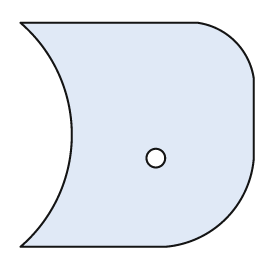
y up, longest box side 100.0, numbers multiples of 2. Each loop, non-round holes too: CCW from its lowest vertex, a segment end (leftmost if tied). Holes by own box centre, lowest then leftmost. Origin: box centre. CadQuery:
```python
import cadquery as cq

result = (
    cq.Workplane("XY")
    .moveTo(-50.0, -48.0)
    .lineTo(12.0, -48.0)
    .threePointArc((38.0, -36.0), (50.0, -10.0))
    .lineTo(50.0, 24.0)
    .threePointArc((42.0, 40.0), (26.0, 48.0))
    .lineTo(-50.0, 48.0)
    .threePointArc((-28.0, 0.0), (-50.0, -48.0))
    .close()
    .moveTo(8.0, -10.0)
    .circle(4.0)
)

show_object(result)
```